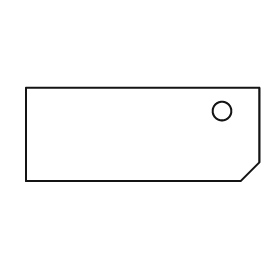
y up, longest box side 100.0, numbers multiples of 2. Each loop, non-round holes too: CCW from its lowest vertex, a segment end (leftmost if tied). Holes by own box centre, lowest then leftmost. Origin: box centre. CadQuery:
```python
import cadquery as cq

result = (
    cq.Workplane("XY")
    .moveTo(-50.0, -20.0)
    .lineTo(42.0, -20.0)
    .lineTo(50.0, -12.0)
    .lineTo(50.0, 20.0)
    .lineTo(-50.0, 20.0)
    .close()
    .moveTo(34.0, 10.0)
    .circle(4.0)
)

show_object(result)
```